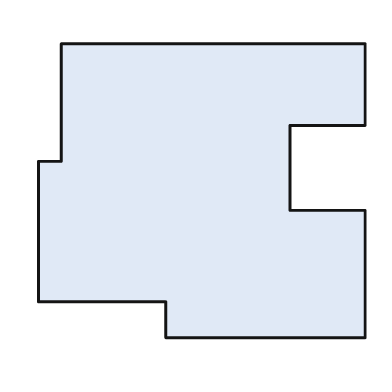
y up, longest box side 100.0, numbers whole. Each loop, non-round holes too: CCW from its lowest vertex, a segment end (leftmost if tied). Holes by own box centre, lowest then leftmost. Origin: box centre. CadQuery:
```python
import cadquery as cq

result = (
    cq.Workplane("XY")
    .moveTo(-11.0, -45.0)
    .lineTo(50.0, -45.0)
    .lineTo(50.0, -6.0)
    .lineTo(27.0, -6.0)
    .lineTo(27.0, 20.0)
    .lineTo(50.0, 20.0)
    .lineTo(50.0, 45.0)
    .lineTo(-43.0, 45.0)
    .lineTo(-43.0, 9.0)
    .lineTo(-50.0, 9.0)
    .lineTo(-50.0, -34.0)
    .lineTo(-11.0, -34.0)
    .close()
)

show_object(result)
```